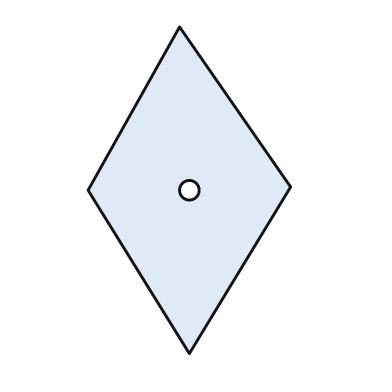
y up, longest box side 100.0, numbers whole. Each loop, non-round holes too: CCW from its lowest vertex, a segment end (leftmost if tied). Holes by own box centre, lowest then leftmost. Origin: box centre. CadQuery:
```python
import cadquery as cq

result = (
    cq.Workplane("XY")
    .moveTo(0.0, -50.0)
    .lineTo(31.0, 1.0)
    .lineTo(-3.0, 50.0)
    .lineTo(-31.0, 0.0)
    .close()
    .moveTo(0.0, 0.0)
    .circle(3.0)
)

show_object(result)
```